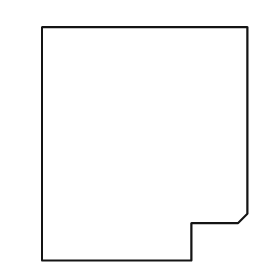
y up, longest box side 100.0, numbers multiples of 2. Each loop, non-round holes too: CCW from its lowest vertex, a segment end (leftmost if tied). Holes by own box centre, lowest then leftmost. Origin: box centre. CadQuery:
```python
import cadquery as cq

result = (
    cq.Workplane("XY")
    .moveTo(-44.0, -50.0)
    .lineTo(20.0, -50.0)
    .lineTo(20.0, -34.0)
    .lineTo(40.0, -34.0)
    .lineTo(44.0, -30.0)
    .lineTo(44.0, 50.0)
    .lineTo(-44.0, 50.0)
    .close()
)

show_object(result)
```